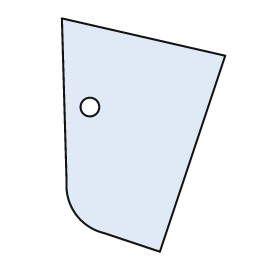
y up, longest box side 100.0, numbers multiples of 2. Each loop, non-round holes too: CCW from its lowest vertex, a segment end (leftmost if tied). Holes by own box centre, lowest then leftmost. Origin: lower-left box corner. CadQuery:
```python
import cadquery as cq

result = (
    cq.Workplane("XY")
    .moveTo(42.0, 0.0)
    .lineTo(70.0, 84.0)
    .lineTo(0.0, 100.0)
    .lineTo(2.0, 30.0)
    .threePointArc((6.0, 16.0), (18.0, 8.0))
    .close()
    .moveTo(12.0, 62.0)
    .circle(4.0)
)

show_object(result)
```